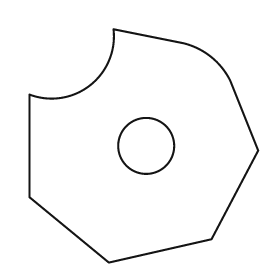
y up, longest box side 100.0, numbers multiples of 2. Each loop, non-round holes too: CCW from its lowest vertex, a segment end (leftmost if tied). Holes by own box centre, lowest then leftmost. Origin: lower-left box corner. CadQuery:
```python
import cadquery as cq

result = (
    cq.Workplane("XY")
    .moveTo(34.0, 0.0)
    .lineTo(78.0, 10.0)
    .lineTo(98.0, 48.0)
    .lineTo(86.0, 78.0)
    .threePointArc((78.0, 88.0), (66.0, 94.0))
    .lineTo(36.0, 100.0)
    .threePointArc((26.0, 76.0), (0.0, 72.0))
    .lineTo(0.0, 28.0)
    .close()
    .moveTo(50.0, 50.0)
    .circle(12.0)
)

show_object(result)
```